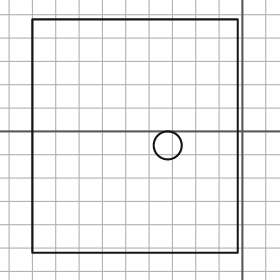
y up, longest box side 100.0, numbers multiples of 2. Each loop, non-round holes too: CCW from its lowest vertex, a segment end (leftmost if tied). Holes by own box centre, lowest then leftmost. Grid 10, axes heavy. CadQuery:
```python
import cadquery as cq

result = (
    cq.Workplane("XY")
    .moveTo(-90.0, -52.0)
    .lineTo(-2.0, -52.0)
    .lineTo(-2.0, 48.0)
    .lineTo(-90.0, 48.0)
    .close()
    .moveTo(-32.0, -6.0)
    .circle(6.0)
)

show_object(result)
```